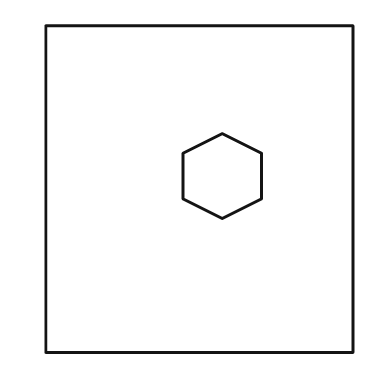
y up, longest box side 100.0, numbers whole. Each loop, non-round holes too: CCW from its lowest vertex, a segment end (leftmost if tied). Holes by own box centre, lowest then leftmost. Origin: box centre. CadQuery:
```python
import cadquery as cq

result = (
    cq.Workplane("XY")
    .moveTo(-47.0, -50.0)
    .lineTo(47.0, -50.0)
    .lineTo(47.0, 50.0)
    .lineTo(-47.0, 50.0)
    .close()
    .moveTo(7.0, -9.0)
    .lineTo(19.0, -3.0)
    .lineTo(19.0, 11.0)
    .lineTo(7.0, 17.0)
    .lineTo(-5.0, 11.0)
    .lineTo(-5.0, -3.0)
    .close()
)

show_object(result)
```